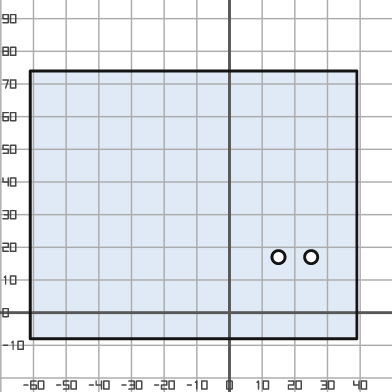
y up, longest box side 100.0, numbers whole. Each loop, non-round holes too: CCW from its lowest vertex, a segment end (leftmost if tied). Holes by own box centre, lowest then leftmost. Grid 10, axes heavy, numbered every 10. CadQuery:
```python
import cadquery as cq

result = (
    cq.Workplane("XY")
    .moveTo(-61.0, -8.0)
    .lineTo(39.0, -8.0)
    .lineTo(39.0, 74.0)
    .lineTo(-61.0, 74.0)
    .close()
    .moveTo(15.0, 17.0)
    .circle(2.0)
    .moveTo(25.0, 17.0)
    .circle(2.0)
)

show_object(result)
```